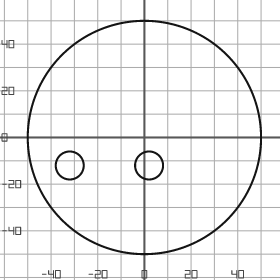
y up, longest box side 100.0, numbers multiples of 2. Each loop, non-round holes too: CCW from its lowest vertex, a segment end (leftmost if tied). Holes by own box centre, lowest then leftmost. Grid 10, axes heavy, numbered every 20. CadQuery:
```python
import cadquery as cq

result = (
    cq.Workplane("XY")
    .moveTo(0.0, 0.0)
    .circle(50.0)
    .moveTo(-32.0, -12.0)
    .circle(6.0)
    .moveTo(2.0, -12.0)
    .circle(6.0)
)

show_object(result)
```